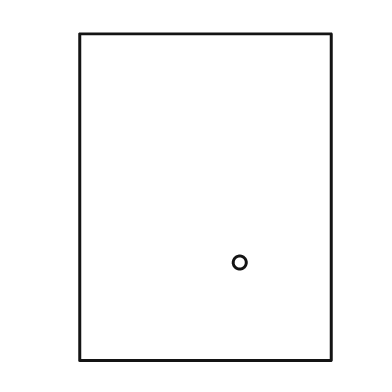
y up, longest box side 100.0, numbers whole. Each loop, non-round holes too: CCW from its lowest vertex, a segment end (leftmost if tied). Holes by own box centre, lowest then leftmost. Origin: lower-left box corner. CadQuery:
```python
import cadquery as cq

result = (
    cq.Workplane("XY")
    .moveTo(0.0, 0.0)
    .lineTo(77.0, 0.0)
    .lineTo(77.0, 100.0)
    .lineTo(0.0, 100.0)
    .close()
    .moveTo(49.0, 30.0)
    .circle(2.0)
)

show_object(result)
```